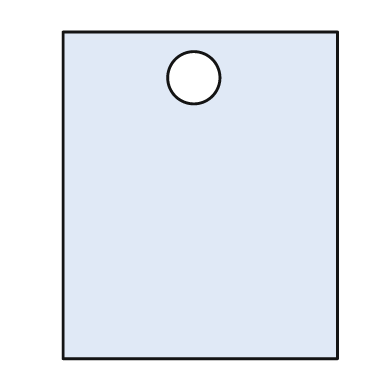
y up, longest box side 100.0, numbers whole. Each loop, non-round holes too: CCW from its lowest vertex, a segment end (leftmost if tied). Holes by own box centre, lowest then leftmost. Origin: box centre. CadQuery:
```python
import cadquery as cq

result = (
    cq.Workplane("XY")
    .moveTo(-42.0, -50.0)
    .lineTo(42.0, -50.0)
    .lineTo(42.0, 50.0)
    .lineTo(-42.0, 50.0)
    .close()
    .moveTo(-2.0, 36.0)
    .circle(8.0)
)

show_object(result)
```